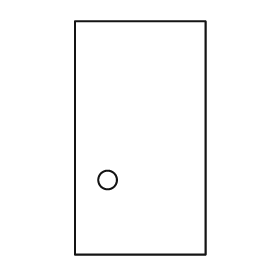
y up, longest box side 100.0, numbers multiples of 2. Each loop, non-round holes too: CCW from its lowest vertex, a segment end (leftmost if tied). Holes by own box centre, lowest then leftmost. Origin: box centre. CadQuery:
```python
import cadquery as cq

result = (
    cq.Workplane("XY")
    .moveTo(-28.0, -50.0)
    .lineTo(28.0, -50.0)
    .lineTo(28.0, 50.0)
    .lineTo(-28.0, 50.0)
    .close()
    .moveTo(-14.0, -18.0)
    .circle(4.0)
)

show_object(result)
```